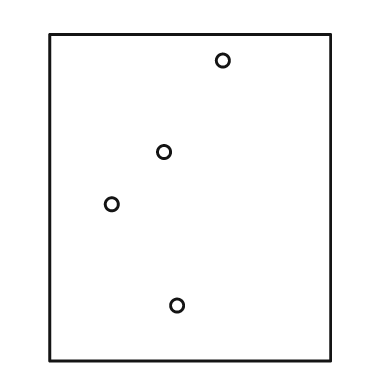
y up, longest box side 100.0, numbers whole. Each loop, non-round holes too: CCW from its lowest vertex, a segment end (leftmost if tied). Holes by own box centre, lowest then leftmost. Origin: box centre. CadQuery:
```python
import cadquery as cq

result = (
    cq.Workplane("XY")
    .moveTo(-43.0, -50.0)
    .lineTo(43.0, -50.0)
    .lineTo(43.0, 50.0)
    .lineTo(-43.0, 50.0)
    .close()
    .moveTo(-4.0, -33.0)
    .circle(2.0)
    .moveTo(-24.0, -2.0)
    .circle(2.0)
    .moveTo(-8.0, 14.0)
    .circle(2.0)
    .moveTo(10.0, 42.0)
    .circle(2.0)
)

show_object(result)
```